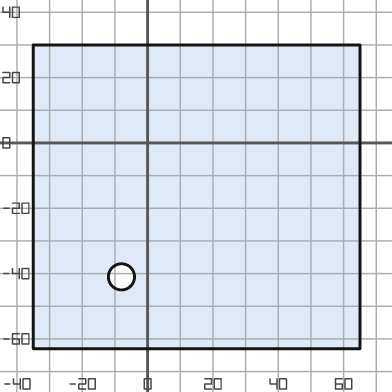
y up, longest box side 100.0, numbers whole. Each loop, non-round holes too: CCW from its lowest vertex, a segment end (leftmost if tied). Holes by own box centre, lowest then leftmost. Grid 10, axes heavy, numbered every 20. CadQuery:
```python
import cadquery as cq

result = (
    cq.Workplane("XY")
    .moveTo(-35.0, -63.0)
    .lineTo(65.0, -63.0)
    .lineTo(65.0, 30.0)
    .lineTo(-35.0, 30.0)
    .close()
    .moveTo(-8.0, -41.0)
    .circle(4.0)
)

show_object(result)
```